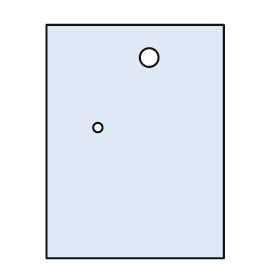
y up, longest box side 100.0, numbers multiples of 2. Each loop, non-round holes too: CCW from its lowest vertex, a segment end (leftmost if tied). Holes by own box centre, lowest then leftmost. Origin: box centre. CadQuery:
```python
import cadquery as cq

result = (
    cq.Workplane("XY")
    .moveTo(-38.0, -50.0)
    .lineTo(38.0, -50.0)
    .lineTo(38.0, 50.0)
    .lineTo(-38.0, 50.0)
    .close()
    .moveTo(-16.0, 6.0)
    .circle(2.0)
    .moveTo(6.0, 36.0)
    .circle(4.0)
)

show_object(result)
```